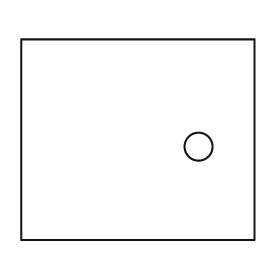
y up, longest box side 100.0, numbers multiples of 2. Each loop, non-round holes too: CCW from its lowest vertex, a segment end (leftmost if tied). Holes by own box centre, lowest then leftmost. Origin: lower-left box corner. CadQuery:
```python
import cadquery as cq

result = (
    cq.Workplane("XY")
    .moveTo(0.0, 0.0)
    .lineTo(100.0, 0.0)
    .lineTo(100.0, 86.0)
    .lineTo(0.0, 86.0)
    .close()
    .moveTo(76.0, 40.0)
    .circle(6.0)
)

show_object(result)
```